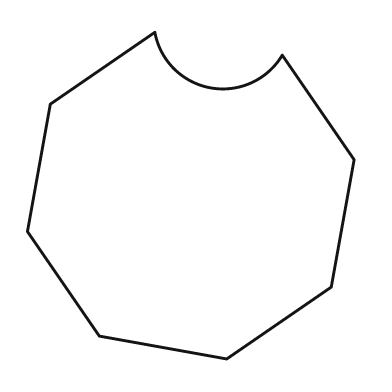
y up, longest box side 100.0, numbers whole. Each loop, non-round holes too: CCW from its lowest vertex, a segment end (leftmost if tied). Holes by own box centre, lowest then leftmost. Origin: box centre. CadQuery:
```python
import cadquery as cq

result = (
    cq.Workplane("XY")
    .moveTo(11.0, -50.0)
    .lineTo(43.0, -28.0)
    .lineTo(50.0, 11.0)
    .lineTo(28.0, 43.0)
    .threePointArc((6.0, 33.0), (-11.0, 50.0))
    .lineTo(-43.0, 28.0)
    .lineTo(-50.0, -11.0)
    .lineTo(-28.0, -43.0)
    .close()
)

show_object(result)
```